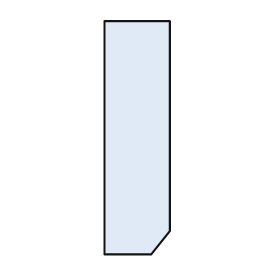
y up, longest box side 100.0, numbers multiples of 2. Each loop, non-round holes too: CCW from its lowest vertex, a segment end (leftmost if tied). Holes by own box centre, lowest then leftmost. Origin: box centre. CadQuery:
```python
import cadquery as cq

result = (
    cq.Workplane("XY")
    .moveTo(-14.0, -50.0)
    .lineTo(6.0, -50.0)
    .lineTo(14.0, -40.0)
    .lineTo(14.0, 50.0)
    .lineTo(-14.0, 50.0)
    .close()
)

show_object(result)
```